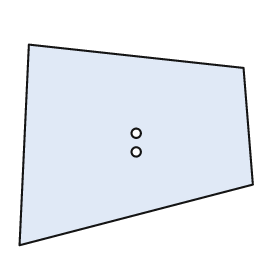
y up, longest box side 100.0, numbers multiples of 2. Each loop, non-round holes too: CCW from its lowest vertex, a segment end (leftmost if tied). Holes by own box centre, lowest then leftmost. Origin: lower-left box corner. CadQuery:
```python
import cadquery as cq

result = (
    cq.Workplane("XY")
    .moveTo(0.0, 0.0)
    .lineTo(100.0, 26.0)
    .lineTo(96.0, 76.0)
    .lineTo(4.0, 86.0)
    .close()
    .moveTo(50.0, 40.0)
    .circle(2.0)
    .moveTo(50.0, 48.0)
    .circle(2.0)
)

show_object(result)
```